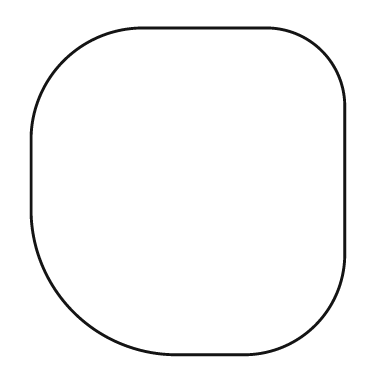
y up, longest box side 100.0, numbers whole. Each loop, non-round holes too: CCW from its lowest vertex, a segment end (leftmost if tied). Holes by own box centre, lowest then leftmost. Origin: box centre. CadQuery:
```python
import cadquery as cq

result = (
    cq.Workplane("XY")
    .moveTo(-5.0, -50.0)
    .lineTo(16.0, -50.0)
    .threePointArc((39.0, -41.0), (48.0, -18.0))
    .lineTo(48.0, 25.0)
    .threePointArc((41.0, 43.0), (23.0, 50.0))
    .lineTo(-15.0, 50.0)
    .threePointArc((-38.0, 40.0), (-48.0, 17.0))
    .lineTo(-48.0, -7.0)
    .threePointArc((-35.0, -37.0), (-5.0, -50.0))
    .close()
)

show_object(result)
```